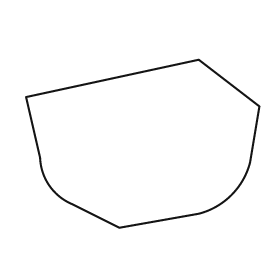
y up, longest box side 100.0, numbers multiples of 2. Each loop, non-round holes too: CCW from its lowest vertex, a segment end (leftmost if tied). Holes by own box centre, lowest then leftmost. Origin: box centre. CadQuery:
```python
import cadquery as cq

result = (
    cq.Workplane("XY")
    .moveTo(-10.0, -36.0)
    .lineTo(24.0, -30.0)
    .threePointArc((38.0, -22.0), (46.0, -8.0))
    .lineTo(50.0, 16.0)
    .lineTo(24.0, 36.0)
    .lineTo(-50.0, 20.0)
    .lineTo(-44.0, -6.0)
    .threePointArc((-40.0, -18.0), (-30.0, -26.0))
    .close()
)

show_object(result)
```